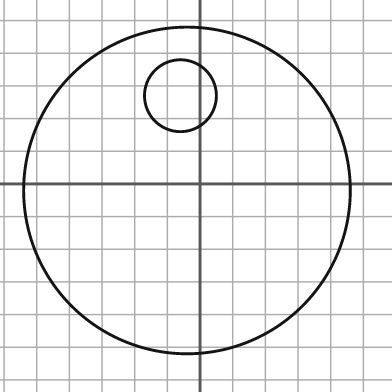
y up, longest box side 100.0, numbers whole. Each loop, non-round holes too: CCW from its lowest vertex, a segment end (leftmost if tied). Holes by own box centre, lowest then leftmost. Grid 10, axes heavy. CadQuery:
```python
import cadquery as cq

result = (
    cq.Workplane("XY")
    .moveTo(-4.0, -2.0)
    .circle(50.0)
    .moveTo(-6.0, 27.0)
    .circle(11.0)
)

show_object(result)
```